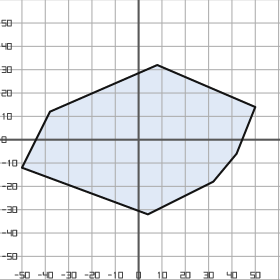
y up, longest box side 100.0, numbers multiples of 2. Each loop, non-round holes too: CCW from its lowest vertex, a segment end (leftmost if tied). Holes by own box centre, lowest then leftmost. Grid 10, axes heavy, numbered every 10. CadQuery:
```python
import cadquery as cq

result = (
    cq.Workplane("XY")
    .moveTo(4.0, -32.0)
    .lineTo(32.0, -18.0)
    .lineTo(42.0, -6.0)
    .lineTo(50.0, 14.0)
    .lineTo(8.0, 32.0)
    .lineTo(-38.0, 12.0)
    .lineTo(-50.0, -12.0)
    .close()
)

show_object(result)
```